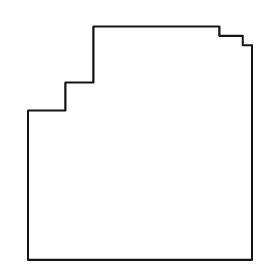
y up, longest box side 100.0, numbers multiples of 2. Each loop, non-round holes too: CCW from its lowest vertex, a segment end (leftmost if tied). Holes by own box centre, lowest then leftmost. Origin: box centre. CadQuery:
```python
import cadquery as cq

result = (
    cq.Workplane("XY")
    .moveTo(-48.0, -50.0)
    .lineTo(48.0, -50.0)
    .lineTo(48.0, 42.0)
    .lineTo(44.0, 42.0)
    .lineTo(44.0, 46.0)
    .lineTo(34.0, 46.0)
    .lineTo(34.0, 50.0)
    .lineTo(-20.0, 50.0)
    .lineTo(-20.0, 26.0)
    .lineTo(-32.0, 26.0)
    .lineTo(-32.0, 14.0)
    .lineTo(-48.0, 14.0)
    .close()
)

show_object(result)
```